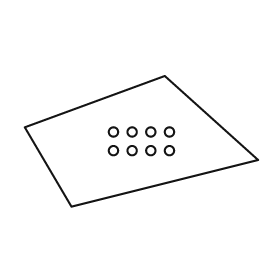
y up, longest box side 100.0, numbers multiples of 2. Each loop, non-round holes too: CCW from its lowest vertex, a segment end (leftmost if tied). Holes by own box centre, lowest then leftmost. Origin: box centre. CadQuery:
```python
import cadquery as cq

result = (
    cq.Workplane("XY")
    .moveTo(-30.0, -28.0)
    .lineTo(50.0, -8.0)
    .lineTo(10.0, 28.0)
    .lineTo(-50.0, 6.0)
    .close()
    .moveTo(-12.0, -4.0)
    .circle(2.0)
    .moveTo(-4.0, -4.0)
    .circle(2.0)
    .moveTo(4.0, -4.0)
    .circle(2.0)
    .moveTo(12.0, -4.0)
    .circle(2.0)
    .moveTo(-12.0, 4.0)
    .circle(2.0)
    .moveTo(-4.0, 4.0)
    .circle(2.0)
    .moveTo(4.0, 4.0)
    .circle(2.0)
    .moveTo(12.0, 4.0)
    .circle(2.0)
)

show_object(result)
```